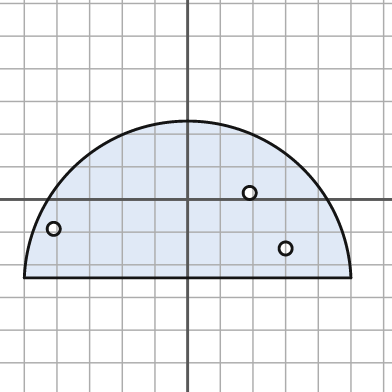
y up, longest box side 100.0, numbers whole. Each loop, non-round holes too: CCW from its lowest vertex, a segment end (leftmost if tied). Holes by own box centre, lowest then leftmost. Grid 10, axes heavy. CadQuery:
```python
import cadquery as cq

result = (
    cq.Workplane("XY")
    .moveTo(-50.0, -24.0)
    .lineTo(50.0, -24.0)
    .threePointArc((0.0, 24.0), (-50.0, -24.0))
    .close()
    .moveTo(30.0, -15.0)
    .circle(2.0)
    .moveTo(-41.0, -9.0)
    .circle(2.0)
    .moveTo(19.0, 2.0)
    .circle(2.0)
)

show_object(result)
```